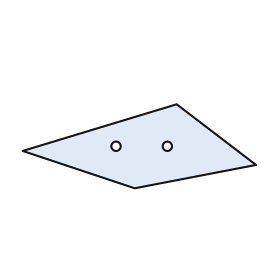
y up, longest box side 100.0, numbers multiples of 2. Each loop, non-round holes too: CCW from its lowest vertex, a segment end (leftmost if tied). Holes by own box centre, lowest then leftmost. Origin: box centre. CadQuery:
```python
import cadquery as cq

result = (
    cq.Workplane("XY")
    .moveTo(-2.0, -18.0)
    .lineTo(50.0, -8.0)
    .lineTo(16.0, 18.0)
    .lineTo(-50.0, -2.0)
    .close()
    .moveTo(-10.0, 0.0)
    .circle(2.0)
    .moveTo(12.0, 0.0)
    .circle(2.0)
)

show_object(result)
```